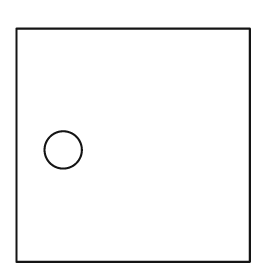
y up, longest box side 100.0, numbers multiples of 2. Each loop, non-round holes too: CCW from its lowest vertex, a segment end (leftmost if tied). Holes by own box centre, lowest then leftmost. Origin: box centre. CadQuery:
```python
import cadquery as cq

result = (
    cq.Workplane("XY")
    .moveTo(-50.0, -50.0)
    .lineTo(50.0, -50.0)
    .lineTo(50.0, 50.0)
    .lineTo(-50.0, 50.0)
    .close()
    .moveTo(-30.0, -2.0)
    .circle(8.0)
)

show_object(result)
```